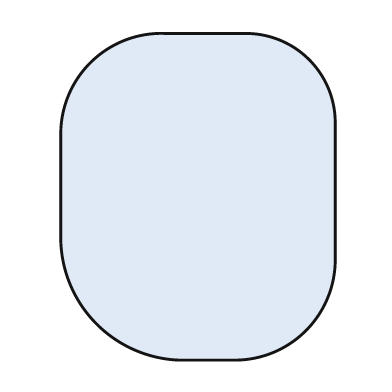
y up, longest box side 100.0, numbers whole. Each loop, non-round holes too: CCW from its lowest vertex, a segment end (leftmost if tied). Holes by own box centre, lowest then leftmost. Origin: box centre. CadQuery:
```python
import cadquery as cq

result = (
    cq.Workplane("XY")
    .moveTo(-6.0, -50.0)
    .lineTo(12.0, -50.0)
    .threePointArc((33.0, -41.0), (42.0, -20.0))
    .lineTo(42.0, 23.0)
    .threePointArc((34.0, 42.0), (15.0, 50.0))
    .lineTo(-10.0, 50.0)
    .threePointArc((-33.0, 41.0), (-42.0, 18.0))
    .lineTo(-42.0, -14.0)
    .threePointArc((-31.0, -39.0), (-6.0, -50.0))
    .close()
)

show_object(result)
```